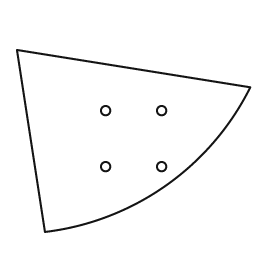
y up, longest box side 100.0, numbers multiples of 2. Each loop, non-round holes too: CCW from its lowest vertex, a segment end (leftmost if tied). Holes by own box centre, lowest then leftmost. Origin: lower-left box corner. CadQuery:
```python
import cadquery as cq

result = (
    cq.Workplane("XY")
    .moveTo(12.0, 0.0)
    .threePointArc((64.0, 20.0), (100.0, 62.0))
    .lineTo(0.0, 78.0)
    .close()
    .moveTo(38.0, 28.0)
    .circle(2.0)
    .moveTo(62.0, 28.0)
    .circle(2.0)
    .moveTo(38.0, 52.0)
    .circle(2.0)
    .moveTo(62.0, 52.0)
    .circle(2.0)
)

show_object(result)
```